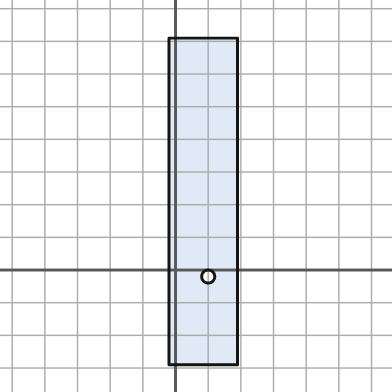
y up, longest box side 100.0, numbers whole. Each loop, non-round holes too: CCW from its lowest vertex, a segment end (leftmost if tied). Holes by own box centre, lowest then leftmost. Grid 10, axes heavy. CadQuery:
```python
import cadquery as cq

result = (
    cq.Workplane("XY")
    .moveTo(-2.0, -29.0)
    .lineTo(19.0, -29.0)
    .lineTo(19.0, 71.0)
    .lineTo(-2.0, 71.0)
    .close()
    .moveTo(10.0, -2.0)
    .circle(2.0)
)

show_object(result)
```